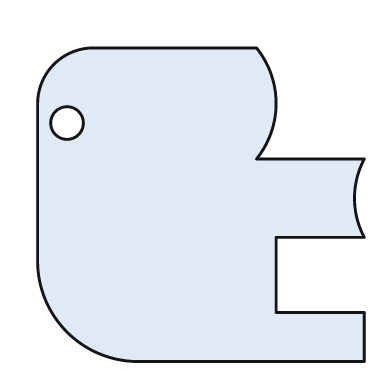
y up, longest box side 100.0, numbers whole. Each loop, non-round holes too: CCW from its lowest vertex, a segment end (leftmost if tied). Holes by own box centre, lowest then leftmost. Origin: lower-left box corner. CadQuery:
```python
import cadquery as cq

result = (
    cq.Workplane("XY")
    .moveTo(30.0, 0.0)
    .lineTo(100.0, 0.0)
    .lineTo(100.0, 15.0)
    .lineTo(73.0, 15.0)
    .lineTo(73.0, 38.0)
    .lineTo(100.0, 38.0)
    .threePointArc((97.0, 50.0), (100.0, 62.0))
    .lineTo(67.0, 62.0)
    .threePointArc((73.0, 79.0), (67.0, 96.0))
    .lineTo(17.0, 96.0)
    .threePointArc((5.0, 91.0), (0.0, 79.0))
    .lineTo(0.0, 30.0)
    .threePointArc((9.0, 9.0), (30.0, 0.0))
    .close()
    .moveTo(9.0, 73.0)
    .circle(5.0)
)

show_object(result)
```